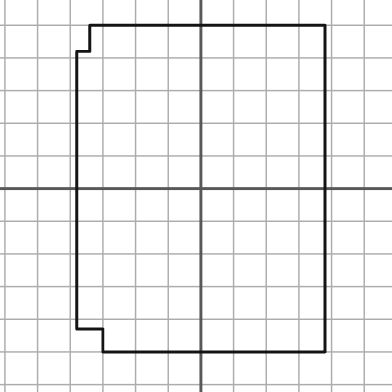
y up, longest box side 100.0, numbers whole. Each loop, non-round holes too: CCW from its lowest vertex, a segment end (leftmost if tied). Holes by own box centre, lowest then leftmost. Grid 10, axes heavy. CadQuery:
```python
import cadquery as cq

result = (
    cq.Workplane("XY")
    .moveTo(-30.0, -50.0)
    .lineTo(38.0, -50.0)
    .lineTo(38.0, 50.0)
    .lineTo(-34.0, 50.0)
    .lineTo(-34.0, 42.0)
    .lineTo(-38.0, 42.0)
    .lineTo(-38.0, -43.0)
    .lineTo(-30.0, -43.0)
    .close()
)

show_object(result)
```